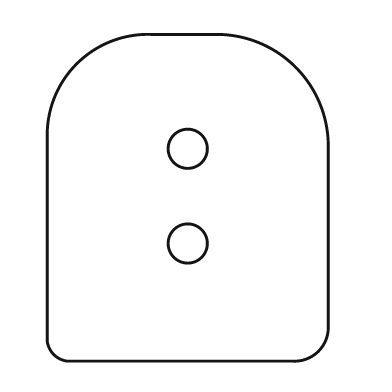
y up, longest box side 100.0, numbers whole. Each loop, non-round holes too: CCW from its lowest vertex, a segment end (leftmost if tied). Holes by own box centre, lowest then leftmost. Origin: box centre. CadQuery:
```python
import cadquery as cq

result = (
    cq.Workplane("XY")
    .moveTo(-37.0, -50.0)
    .lineTo(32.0, -50.0)
    .threePointArc((40.0, -47.0), (43.0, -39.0))
    .lineTo(43.0, 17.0)
    .threePointArc((33.0, 40.0), (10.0, 50.0))
    .lineTo(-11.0, 50.0)
    .threePointArc((-34.0, 41.0), (-43.0, 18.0))
    .lineTo(-43.0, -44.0)
    .threePointArc((-41.0, -48.0), (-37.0, -50.0))
    .close()
    .moveTo(0.0, -14.0)
    .circle(6.0)
    .moveTo(0.0, 15.0)
    .circle(6.0)
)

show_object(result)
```